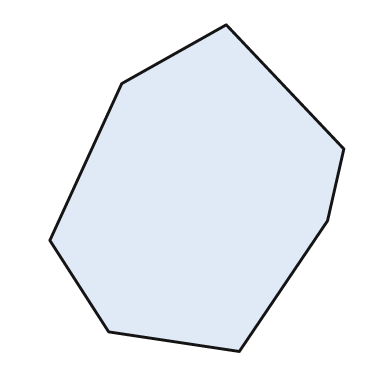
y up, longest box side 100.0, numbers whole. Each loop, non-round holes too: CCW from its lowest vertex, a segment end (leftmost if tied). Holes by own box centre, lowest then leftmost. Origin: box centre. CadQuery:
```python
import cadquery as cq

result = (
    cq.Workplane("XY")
    .moveTo(13.0, -50.0)
    .lineTo(40.0, -10.0)
    .lineTo(45.0, 12.0)
    .lineTo(9.0, 50.0)
    .lineTo(-23.0, 32.0)
    .lineTo(-45.0, -16.0)
    .lineTo(-27.0, -44.0)
    .close()
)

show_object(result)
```